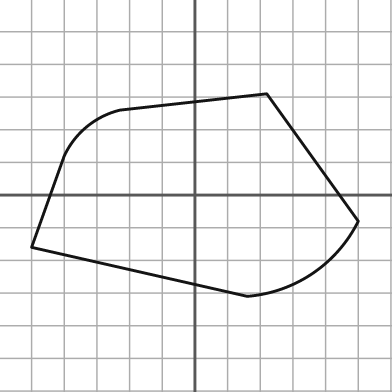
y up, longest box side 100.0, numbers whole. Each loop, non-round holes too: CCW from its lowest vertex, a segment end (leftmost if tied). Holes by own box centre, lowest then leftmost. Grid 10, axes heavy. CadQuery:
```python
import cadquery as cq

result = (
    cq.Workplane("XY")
    .moveTo(16.0, -31.0)
    .threePointArc((36.0, -24.0), (50.0, -8.0))
    .lineTo(22.0, 31.0)
    .lineTo(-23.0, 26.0)
    .threePointArc((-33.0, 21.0), (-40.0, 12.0))
    .lineTo(-50.0, -16.0)
    .close()
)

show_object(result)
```